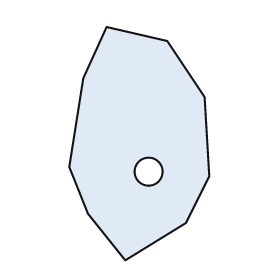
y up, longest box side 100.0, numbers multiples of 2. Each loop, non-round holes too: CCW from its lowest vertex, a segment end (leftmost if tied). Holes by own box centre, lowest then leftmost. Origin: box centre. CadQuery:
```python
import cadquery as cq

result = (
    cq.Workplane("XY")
    .moveTo(-6.0, -50.0)
    .lineTo(20.0, -34.0)
    .lineTo(30.0, -14.0)
    .lineTo(28.0, 20.0)
    .lineTo(12.0, 44.0)
    .lineTo(-14.0, 50.0)
    .lineTo(-24.0, 28.0)
    .lineTo(-30.0, -10.0)
    .lineTo(-22.0, -30.0)
    .close()
    .moveTo(4.0, -12.0)
    .circle(6.0)
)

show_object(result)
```